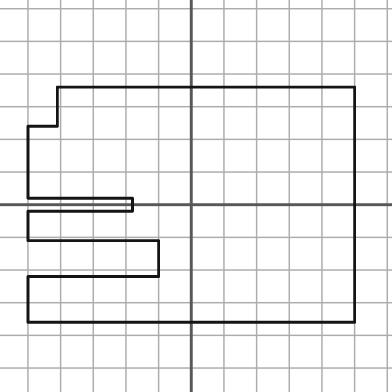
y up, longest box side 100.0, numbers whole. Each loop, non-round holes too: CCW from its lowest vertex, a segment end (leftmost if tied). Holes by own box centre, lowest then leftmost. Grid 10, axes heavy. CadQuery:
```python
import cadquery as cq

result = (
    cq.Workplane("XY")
    .moveTo(-50.0, -36.0)
    .lineTo(50.0, -36.0)
    .lineTo(50.0, 36.0)
    .lineTo(-41.0, 36.0)
    .lineTo(-41.0, 24.0)
    .lineTo(-50.0, 24.0)
    .lineTo(-50.0, 2.0)
    .lineTo(-18.0, 2.0)
    .lineTo(-18.0, -2.0)
    .lineTo(-50.0, -2.0)
    .lineTo(-50.0, -11.0)
    .lineTo(-10.0, -11.0)
    .lineTo(-10.0, -22.0)
    .lineTo(-50.0, -22.0)
    .close()
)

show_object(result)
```